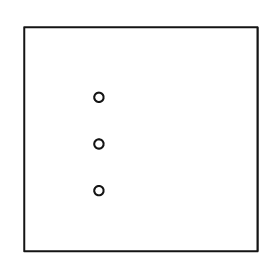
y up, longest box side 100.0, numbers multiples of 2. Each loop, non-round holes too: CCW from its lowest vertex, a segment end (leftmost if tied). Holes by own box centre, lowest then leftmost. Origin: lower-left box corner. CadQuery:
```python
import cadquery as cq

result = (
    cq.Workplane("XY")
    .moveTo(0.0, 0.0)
    .lineTo(100.0, 0.0)
    .lineTo(100.0, 96.0)
    .lineTo(0.0, 96.0)
    .close()
    .moveTo(32.0, 26.0)
    .circle(2.0)
    .moveTo(32.0, 46.0)
    .circle(2.0)
    .moveTo(32.0, 66.0)
    .circle(2.0)
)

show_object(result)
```